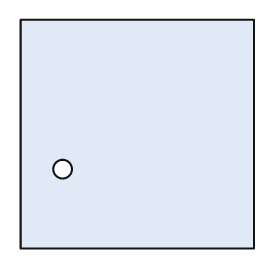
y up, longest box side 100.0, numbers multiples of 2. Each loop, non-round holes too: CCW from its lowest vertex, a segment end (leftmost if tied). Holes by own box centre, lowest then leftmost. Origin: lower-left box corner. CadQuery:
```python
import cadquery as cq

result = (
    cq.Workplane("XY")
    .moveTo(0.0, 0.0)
    .lineTo(100.0, 0.0)
    .lineTo(100.0, 98.0)
    .lineTo(0.0, 98.0)
    .close()
    .moveTo(18.0, 34.0)
    .circle(4.0)
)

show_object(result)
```